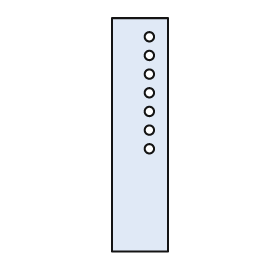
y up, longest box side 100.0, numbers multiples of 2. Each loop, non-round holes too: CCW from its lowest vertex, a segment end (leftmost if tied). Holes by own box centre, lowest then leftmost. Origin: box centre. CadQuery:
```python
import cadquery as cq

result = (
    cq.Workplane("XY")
    .moveTo(-12.0, -50.0)
    .lineTo(12.0, -50.0)
    .lineTo(12.0, 50.0)
    .lineTo(-12.0, 50.0)
    .close()
    .moveTo(4.0, -6.0)
    .circle(2.0)
    .moveTo(4.0, 2.0)
    .circle(2.0)
    .moveTo(4.0, 10.0)
    .circle(2.0)
    .moveTo(4.0, 18.0)
    .circle(2.0)
    .moveTo(4.0, 26.0)
    .circle(2.0)
    .moveTo(4.0, 34.0)
    .circle(2.0)
    .moveTo(4.0, 42.0)
    .circle(2.0)
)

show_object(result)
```